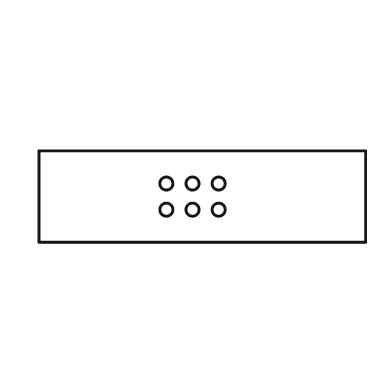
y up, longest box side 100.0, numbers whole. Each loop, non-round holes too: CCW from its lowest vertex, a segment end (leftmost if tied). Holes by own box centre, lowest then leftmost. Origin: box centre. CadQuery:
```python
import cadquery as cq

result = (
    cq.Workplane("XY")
    .moveTo(-50.0, -14.0)
    .lineTo(50.0, -14.0)
    .lineTo(50.0, 14.0)
    .lineTo(-50.0, 14.0)
    .close()
    .moveTo(-11.0, -4.0)
    .circle(2.0)
    .moveTo(-3.0, -4.0)
    .circle(2.0)
    .moveTo(5.0, -4.0)
    .circle(2.0)
    .moveTo(-11.0, 4.0)
    .circle(2.0)
    .moveTo(-3.0, 4.0)
    .circle(2.0)
    .moveTo(5.0, 4.0)
    .circle(2.0)
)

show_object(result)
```